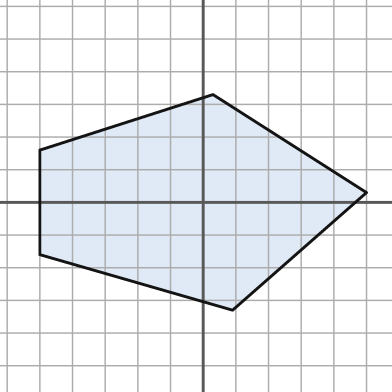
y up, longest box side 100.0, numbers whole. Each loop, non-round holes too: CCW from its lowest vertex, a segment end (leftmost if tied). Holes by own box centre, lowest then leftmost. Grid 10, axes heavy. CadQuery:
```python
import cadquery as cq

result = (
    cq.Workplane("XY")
    .moveTo(9.0, -33.0)
    .lineTo(50.0, 3.0)
    .lineTo(3.0, 33.0)
    .lineTo(-50.0, 16.0)
    .lineTo(-50.0, -16.0)
    .close()
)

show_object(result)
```